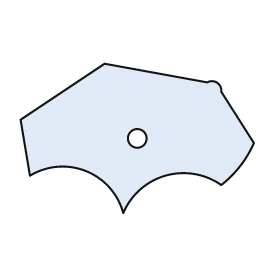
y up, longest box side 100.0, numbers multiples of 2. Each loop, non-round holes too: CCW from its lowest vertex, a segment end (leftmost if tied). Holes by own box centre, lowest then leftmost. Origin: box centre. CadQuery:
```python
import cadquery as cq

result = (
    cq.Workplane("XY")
    .moveTo(-6.0, -32.0)
    .threePointArc((12.0, -16.0), (36.0, -20.0))
    .threePointArc((44.0, -12.0), (50.0, -2.0))
    .lineTo(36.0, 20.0)
    .threePointArc((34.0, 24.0), (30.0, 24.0))
    .lineTo(-14.0, 32.0)
    .lineTo(-50.0, 8.0)
    .lineTo(-46.0, -16.0)
    .threePointArc((-22.0, -14.0), (-6.0, -32.0))
    .close()
    .moveTo(0.0, 0.0)
    .circle(4.0)
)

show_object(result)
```